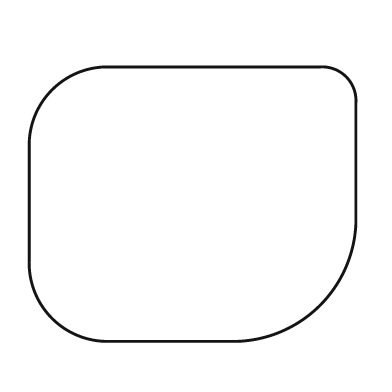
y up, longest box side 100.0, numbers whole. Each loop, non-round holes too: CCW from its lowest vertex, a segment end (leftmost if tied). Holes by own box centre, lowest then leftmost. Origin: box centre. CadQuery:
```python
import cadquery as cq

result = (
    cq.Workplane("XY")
    .moveTo(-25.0, -42.0)
    .lineTo(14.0, -42.0)
    .threePointArc((39.0, -31.0), (50.0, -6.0))
    .lineTo(50.0, 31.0)
    .threePointArc((47.0, 39.0), (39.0, 42.0))
    .lineTo(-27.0, 42.0)
    .threePointArc((-43.0, 35.0), (-50.0, 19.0))
    .lineTo(-50.0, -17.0)
    .threePointArc((-43.0, -35.0), (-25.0, -42.0))
    .close()
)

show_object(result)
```